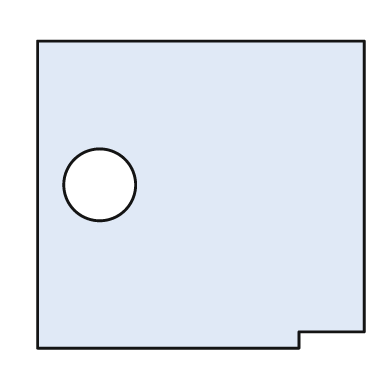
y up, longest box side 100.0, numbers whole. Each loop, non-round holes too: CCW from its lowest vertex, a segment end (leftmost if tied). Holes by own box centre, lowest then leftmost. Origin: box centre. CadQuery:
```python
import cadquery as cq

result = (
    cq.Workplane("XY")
    .moveTo(-50.0, -47.0)
    .lineTo(30.0, -47.0)
    .lineTo(30.0, -42.0)
    .lineTo(50.0, -42.0)
    .lineTo(50.0, 47.0)
    .lineTo(-50.0, 47.0)
    .close()
    .moveTo(-31.0, 3.0)
    .circle(11.0)
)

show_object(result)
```